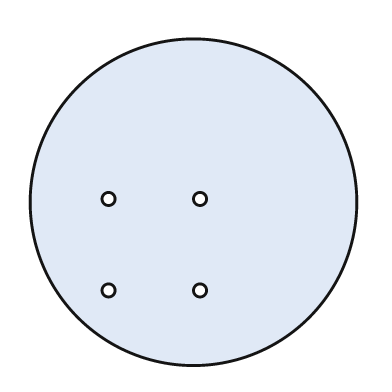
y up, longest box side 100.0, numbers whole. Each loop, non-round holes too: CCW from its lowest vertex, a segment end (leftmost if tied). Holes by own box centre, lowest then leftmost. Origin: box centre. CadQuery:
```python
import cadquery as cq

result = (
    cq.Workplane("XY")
    .moveTo(0.0, 0.0)
    .circle(50.0)
    .moveTo(-26.0, -27.0)
    .circle(2.0)
    .moveTo(2.0, -27.0)
    .circle(2.0)
    .moveTo(-26.0, 1.0)
    .circle(2.0)
    .moveTo(2.0, 1.0)
    .circle(2.0)
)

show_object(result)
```